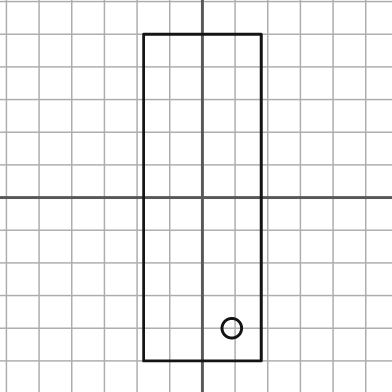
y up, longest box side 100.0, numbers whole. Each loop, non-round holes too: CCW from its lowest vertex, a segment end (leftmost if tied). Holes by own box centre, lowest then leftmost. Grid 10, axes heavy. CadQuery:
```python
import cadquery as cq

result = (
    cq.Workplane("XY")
    .moveTo(-18.0, -50.0)
    .lineTo(18.0, -50.0)
    .lineTo(18.0, 50.0)
    .lineTo(-18.0, 50.0)
    .close()
    .moveTo(9.0, -40.0)
    .circle(3.0)
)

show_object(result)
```